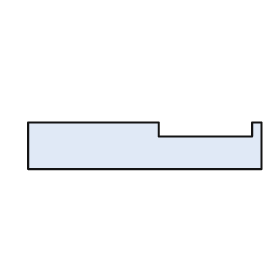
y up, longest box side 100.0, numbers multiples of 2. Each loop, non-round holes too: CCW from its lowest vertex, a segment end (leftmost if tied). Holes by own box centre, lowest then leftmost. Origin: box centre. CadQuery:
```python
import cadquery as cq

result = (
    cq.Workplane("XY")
    .moveTo(-50.0, -10.0)
    .lineTo(50.0, -10.0)
    .lineTo(50.0, 10.0)
    .lineTo(46.0, 10.0)
    .lineTo(46.0, 4.0)
    .lineTo(6.0, 4.0)
    .lineTo(6.0, 10.0)
    .lineTo(-50.0, 10.0)
    .close()
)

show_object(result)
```